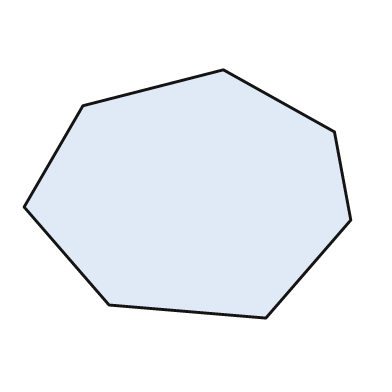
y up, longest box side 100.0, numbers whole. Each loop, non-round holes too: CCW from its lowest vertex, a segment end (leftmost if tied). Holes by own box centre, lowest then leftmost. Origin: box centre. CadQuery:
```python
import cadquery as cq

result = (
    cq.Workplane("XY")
    .moveTo(24.0, -38.0)
    .lineTo(50.0, -8.0)
    .lineTo(45.0, 19.0)
    .lineTo(11.0, 38.0)
    .lineTo(-32.0, 27.0)
    .lineTo(-50.0, -4.0)
    .lineTo(-24.0, -34.0)
    .close()
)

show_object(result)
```